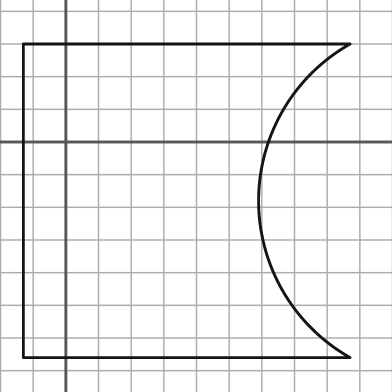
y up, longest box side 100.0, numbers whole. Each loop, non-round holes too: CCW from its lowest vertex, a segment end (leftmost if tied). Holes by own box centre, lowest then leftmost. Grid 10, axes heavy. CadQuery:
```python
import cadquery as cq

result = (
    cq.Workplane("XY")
    .moveTo(-13.0, -66.0)
    .lineTo(87.0, -66.0)
    .threePointArc((59.0, -18.0), (87.0, 30.0))
    .lineTo(-13.0, 30.0)
    .close()
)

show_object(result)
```